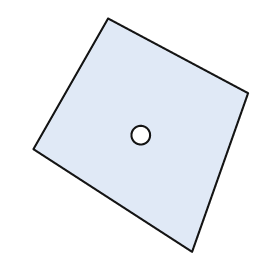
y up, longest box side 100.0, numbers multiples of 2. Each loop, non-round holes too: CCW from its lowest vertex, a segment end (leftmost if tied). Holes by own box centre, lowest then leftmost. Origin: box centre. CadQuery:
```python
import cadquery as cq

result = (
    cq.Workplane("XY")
    .moveTo(22.0, -50.0)
    .lineTo(46.0, 18.0)
    .lineTo(-14.0, 50.0)
    .lineTo(-46.0, -6.0)
    .close()
    .moveTo(0.0, 0.0)
    .circle(4.0)
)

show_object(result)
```